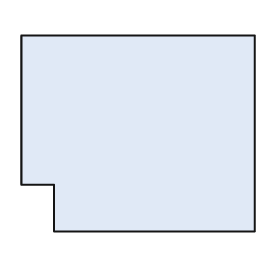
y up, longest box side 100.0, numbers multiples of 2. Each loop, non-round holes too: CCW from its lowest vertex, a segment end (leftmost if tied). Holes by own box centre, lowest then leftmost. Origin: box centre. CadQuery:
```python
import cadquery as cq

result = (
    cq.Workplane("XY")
    .moveTo(-36.0, -42.0)
    .lineTo(50.0, -42.0)
    .lineTo(50.0, 42.0)
    .lineTo(-50.0, 42.0)
    .lineTo(-50.0, -22.0)
    .lineTo(-36.0, -22.0)
    .close()
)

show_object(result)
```